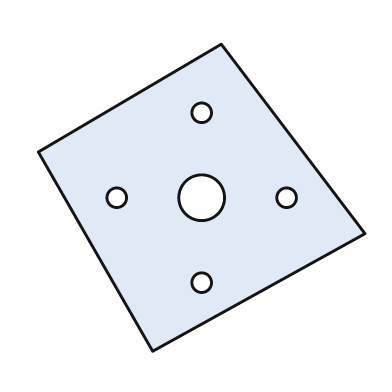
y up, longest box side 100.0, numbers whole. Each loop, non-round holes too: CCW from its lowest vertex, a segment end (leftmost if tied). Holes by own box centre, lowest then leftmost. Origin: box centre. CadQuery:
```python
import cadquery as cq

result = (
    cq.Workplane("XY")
    .moveTo(-15.0, -47.0)
    .lineTo(50.0, -11.0)
    .lineTo(6.0, 47.0)
    .lineTo(-50.0, 14.0)
    .close()
    .moveTo(0.0, -26.0)
    .circle(3.0)
    .moveTo(-26.0, 0.0)
    .circle(3.0)
    .moveTo(0.0, 0.0)
    .circle(7.0)
    .moveTo(26.0, 0.0)
    .circle(3.0)
    .moveTo(0.0, 26.0)
    .circle(3.0)
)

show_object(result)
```